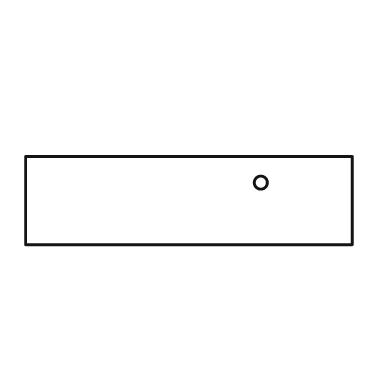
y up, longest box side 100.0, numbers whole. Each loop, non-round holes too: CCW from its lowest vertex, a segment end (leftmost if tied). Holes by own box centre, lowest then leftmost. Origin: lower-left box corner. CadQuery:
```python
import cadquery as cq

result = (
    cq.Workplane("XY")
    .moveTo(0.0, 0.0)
    .lineTo(100.0, 0.0)
    .lineTo(100.0, 27.0)
    .lineTo(0.0, 27.0)
    .close()
    .moveTo(72.0, 19.0)
    .circle(2.0)
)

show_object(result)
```